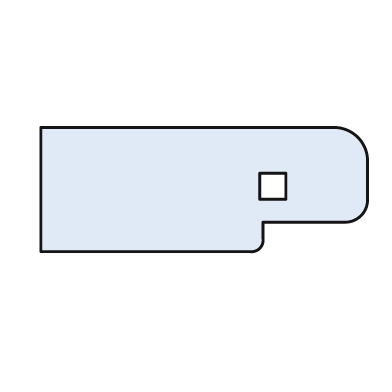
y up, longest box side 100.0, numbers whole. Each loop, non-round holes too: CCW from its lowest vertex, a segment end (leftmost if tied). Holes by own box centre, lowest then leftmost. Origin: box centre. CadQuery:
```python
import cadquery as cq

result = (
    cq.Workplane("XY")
    .moveTo(-50.0, -19.0)
    .lineTo(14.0, -19.0)
    .threePointArc((17.0, -18.0), (18.0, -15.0))
    .lineTo(18.0, -10.0)
    .lineTo(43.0, -10.0)
    .threePointArc((48.0, -8.0), (50.0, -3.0))
    .lineTo(50.0, 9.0)
    .threePointArc((47.0, 16.0), (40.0, 19.0))
    .lineTo(-50.0, 19.0)
    .close()
    .moveTo(17.0, -3.0)
    .lineTo(25.0, -3.0)
    .lineTo(25.0, 5.0)
    .lineTo(17.0, 5.0)
    .close()
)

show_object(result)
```